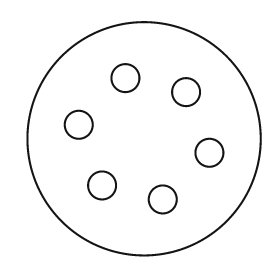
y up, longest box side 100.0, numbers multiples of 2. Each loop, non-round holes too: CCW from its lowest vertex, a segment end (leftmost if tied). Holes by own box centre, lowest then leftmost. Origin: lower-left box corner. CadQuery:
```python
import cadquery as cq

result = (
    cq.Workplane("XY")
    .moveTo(50.0, 50.0)
    .circle(50.0)
    .moveTo(58.0, 24.0)
    .circle(6.0)
    .moveTo(32.0, 30.0)
    .circle(6.0)
    .moveTo(78.0, 44.0)
    .circle(6.0)
    .moveTo(22.0, 56.0)
    .circle(6.0)
    .moveTo(68.0, 70.0)
    .circle(6.0)
    .moveTo(42.0, 76.0)
    .circle(6.0)
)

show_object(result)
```